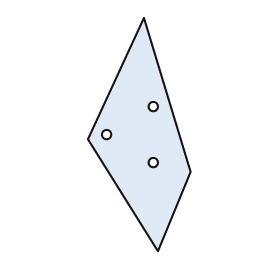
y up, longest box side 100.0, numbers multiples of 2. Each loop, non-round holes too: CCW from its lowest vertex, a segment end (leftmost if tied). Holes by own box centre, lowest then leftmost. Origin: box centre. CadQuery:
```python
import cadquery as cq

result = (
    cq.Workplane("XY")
    .moveTo(8.0, -50.0)
    .lineTo(22.0, -16.0)
    .lineTo(2.0, 50.0)
    .lineTo(-22.0, -2.0)
    .close()
    .moveTo(6.0, -12.0)
    .circle(2.0)
    .moveTo(-14.0, 0.0)
    .circle(2.0)
    .moveTo(6.0, 12.0)
    .circle(2.0)
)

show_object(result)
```